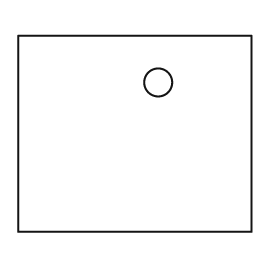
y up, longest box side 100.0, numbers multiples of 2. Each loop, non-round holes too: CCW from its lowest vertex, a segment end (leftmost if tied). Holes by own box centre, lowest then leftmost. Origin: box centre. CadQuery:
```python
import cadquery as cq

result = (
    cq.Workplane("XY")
    .moveTo(-50.0, -42.0)
    .lineTo(50.0, -42.0)
    .lineTo(50.0, 42.0)
    .lineTo(-50.0, 42.0)
    .close()
    .moveTo(10.0, 22.0)
    .circle(6.0)
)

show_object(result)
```